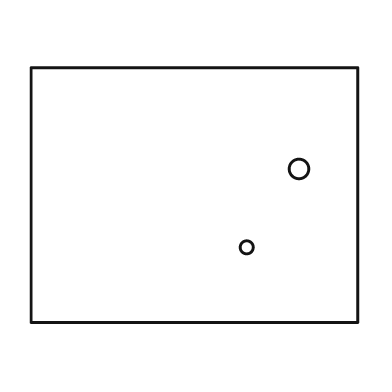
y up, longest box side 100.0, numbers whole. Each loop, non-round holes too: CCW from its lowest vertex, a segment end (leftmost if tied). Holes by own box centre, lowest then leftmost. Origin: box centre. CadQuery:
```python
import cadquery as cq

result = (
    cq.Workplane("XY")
    .moveTo(-50.0, -39.0)
    .lineTo(50.0, -39.0)
    .lineTo(50.0, 39.0)
    .lineTo(-50.0, 39.0)
    .close()
    .moveTo(16.0, -16.0)
    .circle(2.0)
    .moveTo(32.0, 8.0)
    .circle(3.0)
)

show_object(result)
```